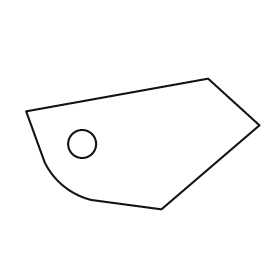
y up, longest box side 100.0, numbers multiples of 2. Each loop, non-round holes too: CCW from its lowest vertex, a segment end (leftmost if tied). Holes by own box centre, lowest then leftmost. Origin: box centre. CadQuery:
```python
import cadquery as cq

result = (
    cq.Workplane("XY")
    .moveTo(8.0, -28.0)
    .lineTo(50.0, 8.0)
    .lineTo(28.0, 28.0)
    .lineTo(-50.0, 14.0)
    .lineTo(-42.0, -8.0)
    .threePointArc((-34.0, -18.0), (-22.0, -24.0))
    .close()
    .moveTo(-26.0, 0.0)
    .circle(6.0)
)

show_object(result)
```